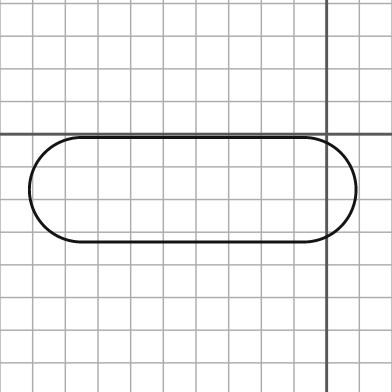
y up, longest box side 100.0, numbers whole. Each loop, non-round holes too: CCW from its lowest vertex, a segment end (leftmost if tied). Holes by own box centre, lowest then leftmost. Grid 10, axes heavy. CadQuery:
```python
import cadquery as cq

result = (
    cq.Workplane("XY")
    .moveTo(-75.0, -33.0)
    .lineTo(-7.0, -33.0)
    .threePointArc((9.0, -17.0), (-7.0, -1.0))
    .lineTo(-75.0, -1.0)
    .threePointArc((-91.0, -17.0), (-75.0, -33.0))
    .close()
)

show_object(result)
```